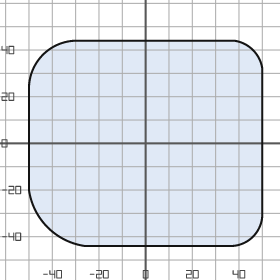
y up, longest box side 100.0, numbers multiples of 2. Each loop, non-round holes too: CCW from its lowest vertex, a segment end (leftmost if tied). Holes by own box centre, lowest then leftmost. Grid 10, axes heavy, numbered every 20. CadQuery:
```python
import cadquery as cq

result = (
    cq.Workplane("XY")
    .moveTo(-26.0, -44.0)
    .lineTo(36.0, -44.0)
    .threePointArc((46.0, -40.0), (50.0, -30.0))
    .lineTo(50.0, 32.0)
    .threePointArc((46.0, 40.0), (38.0, 44.0))
    .lineTo(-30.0, 44.0)
    .threePointArc((-44.0, 38.0), (-50.0, 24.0))
    .lineTo(-50.0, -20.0)
    .threePointArc((-42.0, -36.0), (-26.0, -44.0))
    .close()
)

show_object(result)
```